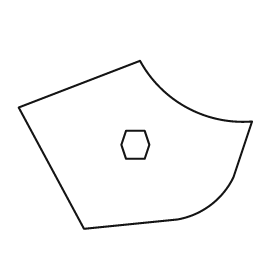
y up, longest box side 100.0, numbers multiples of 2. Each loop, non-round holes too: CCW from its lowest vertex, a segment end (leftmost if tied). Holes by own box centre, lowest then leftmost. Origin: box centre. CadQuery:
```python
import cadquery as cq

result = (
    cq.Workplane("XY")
    .moveTo(-22.0, -36.0)
    .lineTo(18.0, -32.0)
    .threePointArc((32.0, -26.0), (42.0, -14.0))
    .lineTo(50.0, 10.0)
    .threePointArc((22.0, 16.0), (2.0, 36.0))
    .lineTo(-50.0, 16.0)
    .close()
    .moveTo(-4.0, -6.0)
    .lineTo(4.0, -6.0)
    .lineTo(6.0, 0.0)
    .lineTo(4.0, 6.0)
    .lineTo(-4.0, 6.0)
    .lineTo(-6.0, 0.0)
    .close()
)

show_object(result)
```